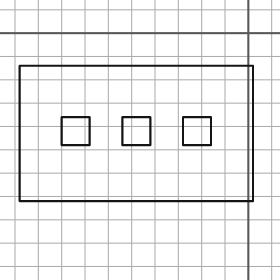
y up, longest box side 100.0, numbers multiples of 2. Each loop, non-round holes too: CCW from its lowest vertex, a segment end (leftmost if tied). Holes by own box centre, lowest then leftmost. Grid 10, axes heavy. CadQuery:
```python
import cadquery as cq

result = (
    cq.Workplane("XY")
    .moveTo(-98.0, -72.0)
    .lineTo(2.0, -72.0)
    .lineTo(2.0, -14.0)
    .lineTo(-98.0, -14.0)
    .close()
    .moveTo(-80.0, -48.0)
    .lineTo(-68.0, -48.0)
    .lineTo(-68.0, -36.0)
    .lineTo(-80.0, -36.0)
    .close()
    .moveTo(-54.0, -48.0)
    .lineTo(-42.0, -48.0)
    .lineTo(-42.0, -36.0)
    .lineTo(-54.0, -36.0)
    .close()
    .moveTo(-28.0, -48.0)
    .lineTo(-16.0, -48.0)
    .lineTo(-16.0, -36.0)
    .lineTo(-28.0, -36.0)
    .close()
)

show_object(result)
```